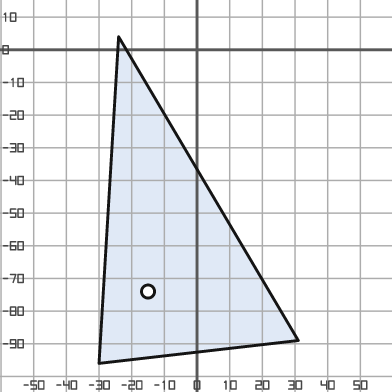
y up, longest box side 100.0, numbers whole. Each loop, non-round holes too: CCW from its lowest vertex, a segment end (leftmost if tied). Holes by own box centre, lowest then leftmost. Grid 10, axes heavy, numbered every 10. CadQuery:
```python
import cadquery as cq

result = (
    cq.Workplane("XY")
    .moveTo(-30.0, -96.0)
    .lineTo(31.0, -89.0)
    .lineTo(-24.0, 4.0)
    .close()
    .moveTo(-15.0, -74.0)
    .circle(2.0)
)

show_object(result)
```